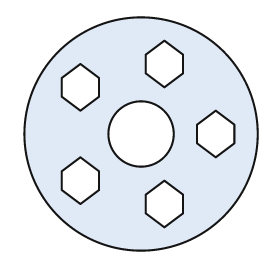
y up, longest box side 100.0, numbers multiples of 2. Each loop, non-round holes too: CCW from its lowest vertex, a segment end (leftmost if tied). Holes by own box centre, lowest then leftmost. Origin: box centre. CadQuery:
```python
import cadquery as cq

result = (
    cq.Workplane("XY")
    .moveTo(0.0, 0.0)
    .circle(50.0)
    .moveTo(10.0, -40.0)
    .lineTo(18.0, -34.0)
    .lineTo(18.0, -26.0)
    .lineTo(10.0, -20.0)
    .lineTo(2.0, -26.0)
    .lineTo(2.0, -34.0)
    .close()
    .moveTo(-26.0, -30.0)
    .lineTo(-18.0, -24.0)
    .lineTo(-18.0, -16.0)
    .lineTo(-26.0, -10.0)
    .lineTo(-34.0, -16.0)
    .lineTo(-34.0, -24.0)
    .close()
    .moveTo(0.0, 0.0)
    .circle(14.0)
    .moveTo(32.0, -10.0)
    .lineTo(40.0, -4.0)
    .lineTo(40.0, 4.0)
    .lineTo(32.0, 10.0)
    .lineTo(24.0, 4.0)
    .lineTo(24.0, -4.0)
    .close()
    .moveTo(-26.0, 10.0)
    .lineTo(-18.0, 16.0)
    .lineTo(-18.0, 24.0)
    .lineTo(-26.0, 30.0)
    .lineTo(-34.0, 24.0)
    .lineTo(-34.0, 16.0)
    .close()
    .moveTo(10.0, 20.0)
    .lineTo(18.0, 26.0)
    .lineTo(18.0, 34.0)
    .lineTo(10.0, 40.0)
    .lineTo(2.0, 34.0)
    .lineTo(2.0, 26.0)
    .close()
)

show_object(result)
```